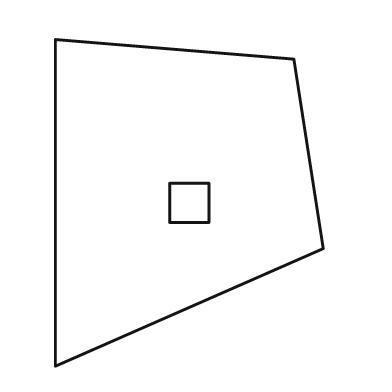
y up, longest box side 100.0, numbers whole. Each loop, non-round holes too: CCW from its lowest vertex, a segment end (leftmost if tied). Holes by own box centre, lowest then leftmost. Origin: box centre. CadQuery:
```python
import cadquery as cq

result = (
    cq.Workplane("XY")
    .moveTo(-41.0, -50.0)
    .lineTo(41.0, -14.0)
    .lineTo(32.0, 44.0)
    .lineTo(-41.0, 50.0)
    .close()
    .moveTo(-6.0, -6.0)
    .lineTo(6.0, -6.0)
    .lineTo(6.0, 6.0)
    .lineTo(-6.0, 6.0)
    .close()
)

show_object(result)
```